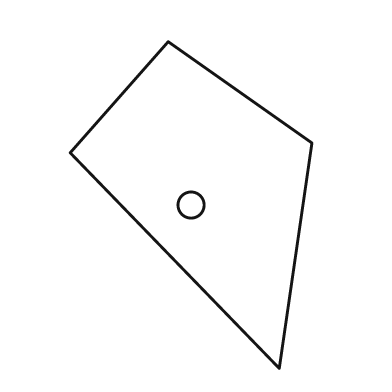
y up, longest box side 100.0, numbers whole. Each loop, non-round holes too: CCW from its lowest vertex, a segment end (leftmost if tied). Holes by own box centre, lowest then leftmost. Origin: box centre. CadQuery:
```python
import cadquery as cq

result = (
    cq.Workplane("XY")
    .moveTo(27.0, -50.0)
    .lineTo(37.0, 19.0)
    .lineTo(-7.0, 50.0)
    .lineTo(-37.0, 16.0)
    .close()
    .moveTo(0.0, 0.0)
    .circle(4.0)
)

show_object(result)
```